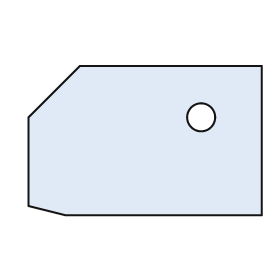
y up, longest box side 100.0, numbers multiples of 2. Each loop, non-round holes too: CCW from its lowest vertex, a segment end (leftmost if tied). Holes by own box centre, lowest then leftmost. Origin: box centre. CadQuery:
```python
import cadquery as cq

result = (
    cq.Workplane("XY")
    .moveTo(-34.0, -32.0)
    .lineTo(50.0, -32.0)
    .lineTo(50.0, 32.0)
    .lineTo(-28.0, 32.0)
    .lineTo(-50.0, 10.0)
    .lineTo(-50.0, -28.0)
    .close()
    .moveTo(24.0, 10.0)
    .circle(6.0)
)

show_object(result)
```